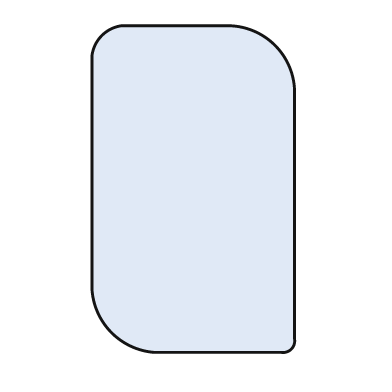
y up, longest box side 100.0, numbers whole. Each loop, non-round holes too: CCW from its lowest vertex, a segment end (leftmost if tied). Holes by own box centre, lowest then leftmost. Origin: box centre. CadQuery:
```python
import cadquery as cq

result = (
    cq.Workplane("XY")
    .moveTo(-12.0, -50.0)
    .lineTo(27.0, -50.0)
    .threePointArc((30.0, -49.0), (31.0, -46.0))
    .lineTo(31.0, 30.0)
    .threePointArc((25.0, 44.0), (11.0, 50.0))
    .lineTo(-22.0, 50.0)
    .threePointArc((-28.0, 47.0), (-31.0, 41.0))
    .lineTo(-31.0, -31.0)
    .threePointArc((-25.0, -44.0), (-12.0, -50.0))
    .close()
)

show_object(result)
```